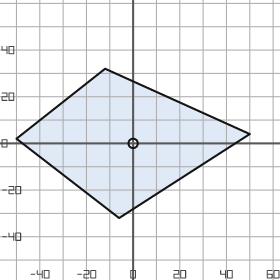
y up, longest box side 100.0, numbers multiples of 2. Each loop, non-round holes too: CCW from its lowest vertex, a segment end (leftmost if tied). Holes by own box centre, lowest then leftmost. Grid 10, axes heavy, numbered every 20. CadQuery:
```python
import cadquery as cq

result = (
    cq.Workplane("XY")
    .moveTo(-6.0, -32.0)
    .lineTo(50.0, 4.0)
    .lineTo(-12.0, 32.0)
    .lineTo(-50.0, 2.0)
    .close()
    .moveTo(0.0, 0.0)
    .circle(2.0)
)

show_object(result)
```